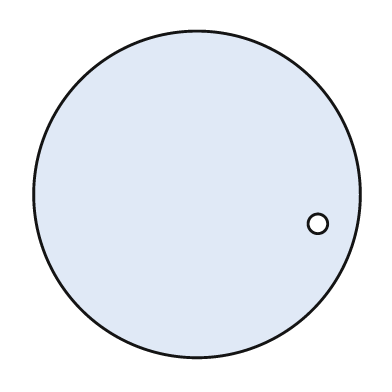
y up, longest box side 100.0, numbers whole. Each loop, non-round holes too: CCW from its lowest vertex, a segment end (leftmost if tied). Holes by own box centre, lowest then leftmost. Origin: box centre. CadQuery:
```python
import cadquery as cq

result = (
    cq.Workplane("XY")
    .moveTo(0.0, 0.0)
    .circle(50.0)
    .moveTo(37.0, -9.0)
    .circle(3.0)
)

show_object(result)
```